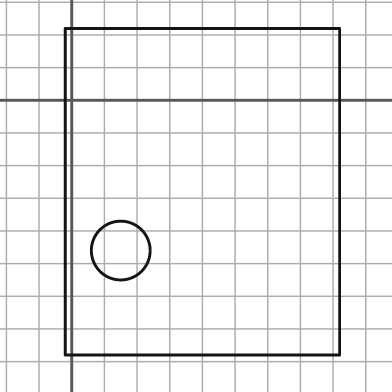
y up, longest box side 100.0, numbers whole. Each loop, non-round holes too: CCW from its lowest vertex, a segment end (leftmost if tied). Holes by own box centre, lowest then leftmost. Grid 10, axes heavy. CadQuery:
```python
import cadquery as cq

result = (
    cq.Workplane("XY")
    .moveTo(-2.0, -78.0)
    .lineTo(82.0, -78.0)
    .lineTo(82.0, 22.0)
    .lineTo(-2.0, 22.0)
    .close()
    .moveTo(15.0, -46.0)
    .circle(9.0)
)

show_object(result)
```